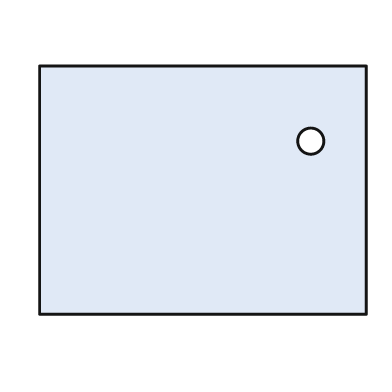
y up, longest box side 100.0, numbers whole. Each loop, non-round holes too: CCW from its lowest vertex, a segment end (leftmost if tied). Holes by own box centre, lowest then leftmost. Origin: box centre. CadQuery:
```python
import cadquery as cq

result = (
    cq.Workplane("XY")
    .moveTo(-50.0, -38.0)
    .lineTo(50.0, -38.0)
    .lineTo(50.0, 38.0)
    .lineTo(-50.0, 38.0)
    .close()
    .moveTo(33.0, 15.0)
    .circle(4.0)
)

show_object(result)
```